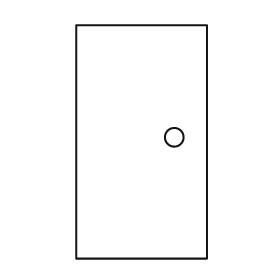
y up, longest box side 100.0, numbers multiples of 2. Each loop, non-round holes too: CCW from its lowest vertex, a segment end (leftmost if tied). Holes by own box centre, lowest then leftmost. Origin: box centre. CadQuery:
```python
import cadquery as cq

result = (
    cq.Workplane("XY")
    .moveTo(-28.0, -50.0)
    .lineTo(28.0, -50.0)
    .lineTo(28.0, 50.0)
    .lineTo(-28.0, 50.0)
    .close()
    .moveTo(14.0, 2.0)
    .circle(4.0)
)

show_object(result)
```